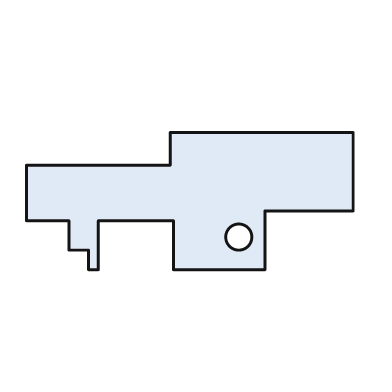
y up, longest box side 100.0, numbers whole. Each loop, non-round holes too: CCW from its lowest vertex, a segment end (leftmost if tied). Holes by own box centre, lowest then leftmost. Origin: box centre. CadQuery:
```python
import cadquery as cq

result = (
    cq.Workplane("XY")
    .moveTo(-31.0, -21.0)
    .lineTo(-28.0, -21.0)
    .lineTo(-28.0, -6.0)
    .lineTo(-5.0, -6.0)
    .lineTo(-5.0, -21.0)
    .lineTo(23.0, -21.0)
    .lineTo(23.0, -3.0)
    .lineTo(50.0, -3.0)
    .lineTo(50.0, 21.0)
    .lineTo(-6.0, 21.0)
    .lineTo(-6.0, 11.0)
    .lineTo(-50.0, 11.0)
    .lineTo(-50.0, -6.0)
    .lineTo(-37.0, -6.0)
    .lineTo(-37.0, -15.0)
    .lineTo(-31.0, -15.0)
    .close()
    .moveTo(15.0, -11.0)
    .circle(4.0)
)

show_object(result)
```